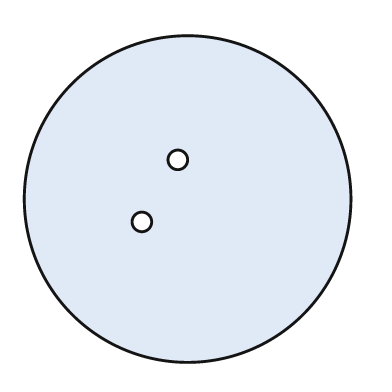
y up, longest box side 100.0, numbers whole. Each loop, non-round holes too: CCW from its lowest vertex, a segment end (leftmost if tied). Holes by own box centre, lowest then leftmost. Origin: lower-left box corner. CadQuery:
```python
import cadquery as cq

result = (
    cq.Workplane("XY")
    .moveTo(50.0, 50.0)
    .circle(50.0)
    .moveTo(36.0, 43.0)
    .circle(3.0)
    .moveTo(47.0, 62.0)
    .circle(3.0)
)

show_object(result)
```